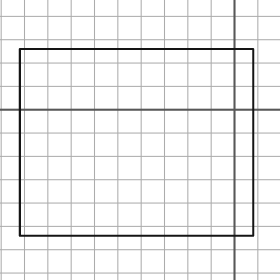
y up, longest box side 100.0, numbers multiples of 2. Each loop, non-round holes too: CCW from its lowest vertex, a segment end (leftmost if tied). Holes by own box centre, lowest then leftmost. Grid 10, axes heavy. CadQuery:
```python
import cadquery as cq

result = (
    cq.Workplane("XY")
    .moveTo(-92.0, -54.0)
    .lineTo(8.0, -54.0)
    .lineTo(8.0, 26.0)
    .lineTo(-92.0, 26.0)
    .close()
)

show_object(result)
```